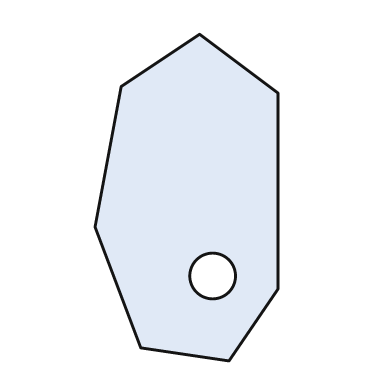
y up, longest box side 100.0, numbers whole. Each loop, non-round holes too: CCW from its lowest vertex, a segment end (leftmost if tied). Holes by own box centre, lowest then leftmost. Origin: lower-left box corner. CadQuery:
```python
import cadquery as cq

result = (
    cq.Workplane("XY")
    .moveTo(41.0, 0.0)
    .lineTo(56.0, 22.0)
    .lineTo(56.0, 82.0)
    .lineTo(32.0, 100.0)
    .lineTo(8.0, 84.0)
    .lineTo(0.0, 41.0)
    .lineTo(14.0, 4.0)
    .close()
    .moveTo(36.0, 26.0)
    .circle(7.0)
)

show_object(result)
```